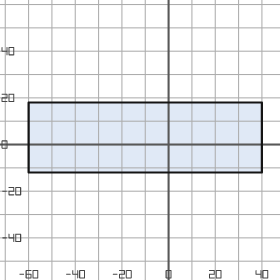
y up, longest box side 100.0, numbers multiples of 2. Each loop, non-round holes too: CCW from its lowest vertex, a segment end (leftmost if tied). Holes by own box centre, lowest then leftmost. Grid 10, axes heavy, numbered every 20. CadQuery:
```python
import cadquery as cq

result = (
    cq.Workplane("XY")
    .moveTo(-60.0, -12.0)
    .lineTo(40.0, -12.0)
    .lineTo(40.0, 18.0)
    .lineTo(-60.0, 18.0)
    .close()
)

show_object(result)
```